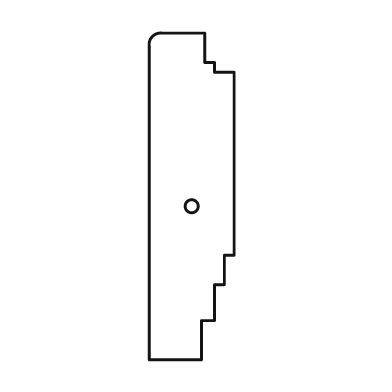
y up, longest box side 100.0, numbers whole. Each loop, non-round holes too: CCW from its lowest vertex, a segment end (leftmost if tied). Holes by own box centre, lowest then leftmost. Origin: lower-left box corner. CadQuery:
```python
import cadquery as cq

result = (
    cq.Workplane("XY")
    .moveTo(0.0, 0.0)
    .lineTo(16.0, 0.0)
    .lineTo(16.0, 12.0)
    .lineTo(20.0, 12.0)
    .lineTo(20.0, 23.0)
    .lineTo(23.0, 23.0)
    .lineTo(23.0, 32.0)
    .lineTo(26.0, 32.0)
    .lineTo(26.0, 88.0)
    .lineTo(20.0, 88.0)
    .lineTo(20.0, 91.0)
    .lineTo(17.0, 91.0)
    .lineTo(17.0, 100.0)
    .lineTo(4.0, 100.0)
    .threePointArc((1.0, 99.0), (0.0, 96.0))
    .close()
    .moveTo(13.0, 47.0)
    .circle(2.0)
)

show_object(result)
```